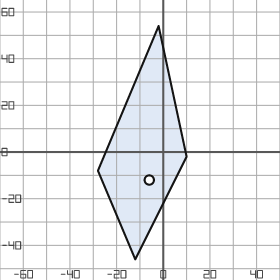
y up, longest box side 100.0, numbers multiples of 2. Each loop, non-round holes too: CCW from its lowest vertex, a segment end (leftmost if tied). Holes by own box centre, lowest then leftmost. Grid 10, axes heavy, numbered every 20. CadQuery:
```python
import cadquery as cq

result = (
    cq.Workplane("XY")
    .moveTo(-12.0, -46.0)
    .lineTo(10.0, -2.0)
    .lineTo(-2.0, 54.0)
    .lineTo(-28.0, -8.0)
    .close()
    .moveTo(-6.0, -12.0)
    .circle(2.0)
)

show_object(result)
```